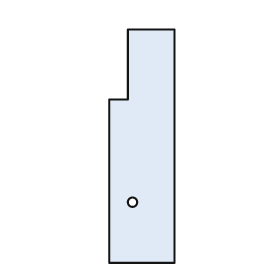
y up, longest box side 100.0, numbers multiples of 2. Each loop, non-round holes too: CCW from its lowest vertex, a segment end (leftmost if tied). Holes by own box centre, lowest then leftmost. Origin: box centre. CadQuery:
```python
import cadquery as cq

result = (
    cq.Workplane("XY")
    .moveTo(-14.0, -50.0)
    .lineTo(14.0, -50.0)
    .lineTo(14.0, 50.0)
    .lineTo(-6.0, 50.0)
    .lineTo(-6.0, 20.0)
    .lineTo(-14.0, 20.0)
    .close()
    .moveTo(-4.0, -24.0)
    .circle(2.0)
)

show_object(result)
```